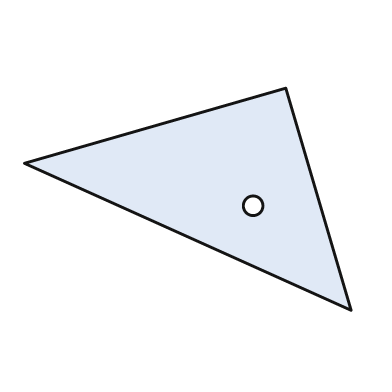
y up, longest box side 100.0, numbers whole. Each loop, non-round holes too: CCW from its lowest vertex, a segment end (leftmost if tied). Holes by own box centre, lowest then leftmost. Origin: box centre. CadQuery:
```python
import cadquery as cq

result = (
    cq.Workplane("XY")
    .moveTo(50.0, -34.0)
    .lineTo(30.0, 34.0)
    .lineTo(-50.0, 11.0)
    .close()
    .moveTo(20.0, -2.0)
    .circle(3.0)
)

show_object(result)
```